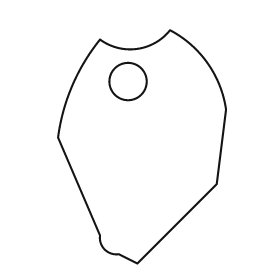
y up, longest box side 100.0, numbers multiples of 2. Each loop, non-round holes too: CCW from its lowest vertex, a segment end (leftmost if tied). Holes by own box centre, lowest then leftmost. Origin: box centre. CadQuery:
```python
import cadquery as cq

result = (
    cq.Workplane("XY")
    .moveTo(-2.0, -50.0)
    .lineTo(32.0, -16.0)
    .lineTo(36.0, 16.0)
    .threePointArc((28.0, 36.0), (12.0, 50.0))
    .threePointArc((-2.0, 42.0), (-18.0, 46.0))
    .threePointArc((-30.0, 26.0), (-36.0, 4.0))
    .lineTo(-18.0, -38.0)
    .threePointArc((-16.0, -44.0), (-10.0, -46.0))
    .close()
    .moveTo(-6.0, 28.0)
    .circle(8.0)
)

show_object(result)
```